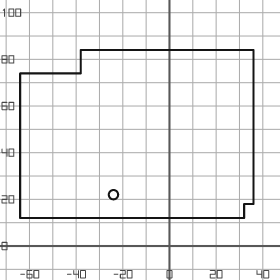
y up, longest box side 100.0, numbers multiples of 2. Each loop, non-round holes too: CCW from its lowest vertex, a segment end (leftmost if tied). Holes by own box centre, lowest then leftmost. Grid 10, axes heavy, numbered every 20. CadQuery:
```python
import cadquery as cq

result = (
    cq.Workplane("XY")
    .moveTo(-64.0, 12.0)
    .lineTo(32.0, 12.0)
    .lineTo(32.0, 18.0)
    .lineTo(36.0, 18.0)
    .lineTo(36.0, 84.0)
    .lineTo(-38.0, 84.0)
    .lineTo(-38.0, 74.0)
    .lineTo(-64.0, 74.0)
    .close()
    .moveTo(-24.0, 22.0)
    .circle(2.0)
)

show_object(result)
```